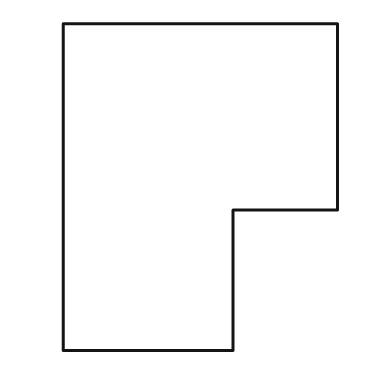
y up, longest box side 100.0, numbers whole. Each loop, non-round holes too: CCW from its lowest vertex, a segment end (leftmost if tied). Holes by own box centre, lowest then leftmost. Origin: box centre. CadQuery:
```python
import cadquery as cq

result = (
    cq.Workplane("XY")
    .moveTo(-42.0, -50.0)
    .lineTo(10.0, -50.0)
    .lineTo(10.0, -7.0)
    .lineTo(42.0, -7.0)
    .lineTo(42.0, 50.0)
    .lineTo(-42.0, 50.0)
    .close()
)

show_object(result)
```